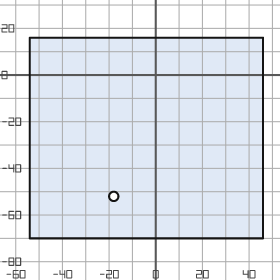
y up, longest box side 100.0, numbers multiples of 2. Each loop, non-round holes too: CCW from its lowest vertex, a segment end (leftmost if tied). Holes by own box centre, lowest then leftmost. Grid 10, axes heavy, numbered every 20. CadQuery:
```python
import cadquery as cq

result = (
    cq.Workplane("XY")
    .moveTo(-54.0, -70.0)
    .lineTo(46.0, -70.0)
    .lineTo(46.0, 16.0)
    .lineTo(-54.0, 16.0)
    .close()
    .moveTo(-18.0, -52.0)
    .circle(2.0)
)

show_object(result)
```